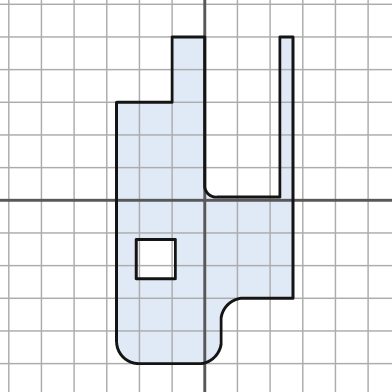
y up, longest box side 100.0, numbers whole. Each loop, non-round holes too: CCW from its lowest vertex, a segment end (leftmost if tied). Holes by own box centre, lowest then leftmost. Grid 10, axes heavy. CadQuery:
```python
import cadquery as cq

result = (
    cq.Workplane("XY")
    .moveTo(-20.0, -50.0)
    .lineTo(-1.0, -50.0)
    .threePointArc((3.0, -48.0), (5.0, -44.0))
    .lineTo(5.0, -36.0)
    .threePointArc((7.0, -32.0), (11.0, -30.0))
    .lineTo(27.0, -30.0)
    .lineTo(27.0, 50.0)
    .lineTo(23.0, 50.0)
    .lineTo(23.0, 1.0)
    .lineTo(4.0, 1.0)
    .threePointArc((1.0, 2.0), (0.0, 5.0))
    .lineTo(0.0, 50.0)
    .lineTo(-10.0, 50.0)
    .lineTo(-10.0, 30.0)
    .lineTo(-27.0, 30.0)
    .lineTo(-27.0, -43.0)
    .threePointArc((-25.0, -48.0), (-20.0, -50.0))
    .close()
    .moveTo(-21.0, -24.0)
    .lineTo(-9.0, -24.0)
    .lineTo(-9.0, -12.0)
    .lineTo(-21.0, -12.0)
    .close()
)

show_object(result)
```